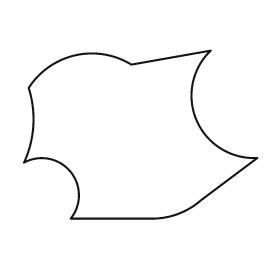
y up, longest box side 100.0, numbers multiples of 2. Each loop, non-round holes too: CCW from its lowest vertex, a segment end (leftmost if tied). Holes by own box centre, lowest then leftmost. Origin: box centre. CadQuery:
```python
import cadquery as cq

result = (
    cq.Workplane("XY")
    .moveTo(-30.0, -36.0)
    .lineTo(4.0, -36.0)
    .threePointArc((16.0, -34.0), (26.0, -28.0))
    .lineTo(50.0, -10.0)
    .threePointArc((24.0, 6.0), (30.0, 36.0))
    .lineTo(-4.0, 30.0)
    .threePointArc((-28.0, 34.0), (-48.0, 20.0))
    .threePointArc((-46.0, 4.0), (-50.0, -12.0))
    .threePointArc((-30.0, -16.0), (-30.0, -36.0))
    .close()
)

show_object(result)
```